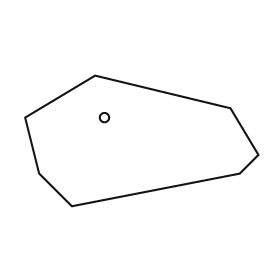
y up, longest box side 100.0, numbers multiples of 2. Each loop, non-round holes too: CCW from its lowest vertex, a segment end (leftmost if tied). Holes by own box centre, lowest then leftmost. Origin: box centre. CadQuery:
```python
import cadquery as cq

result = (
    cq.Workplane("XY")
    .moveTo(-30.0, -28.0)
    .lineTo(42.0, -14.0)
    .lineTo(50.0, -6.0)
    .lineTo(38.0, 14.0)
    .lineTo(-20.0, 28.0)
    .lineTo(-50.0, 10.0)
    .lineTo(-44.0, -14.0)
    .close()
    .moveTo(-16.0, 10.0)
    .circle(2.0)
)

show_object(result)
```